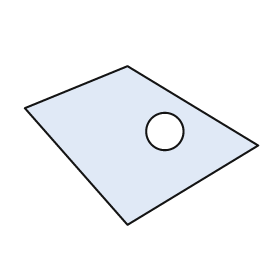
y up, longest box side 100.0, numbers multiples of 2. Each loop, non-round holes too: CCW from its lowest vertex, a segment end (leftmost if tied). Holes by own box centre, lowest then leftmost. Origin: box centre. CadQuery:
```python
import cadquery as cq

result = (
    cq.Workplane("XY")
    .moveTo(-6.0, -34.0)
    .lineTo(50.0, 0.0)
    .lineTo(-6.0, 34.0)
    .lineTo(-50.0, 16.0)
    .close()
    .moveTo(10.0, 6.0)
    .circle(8.0)
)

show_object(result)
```